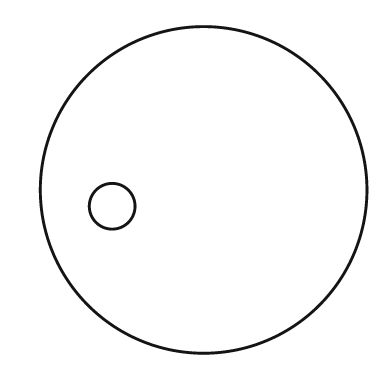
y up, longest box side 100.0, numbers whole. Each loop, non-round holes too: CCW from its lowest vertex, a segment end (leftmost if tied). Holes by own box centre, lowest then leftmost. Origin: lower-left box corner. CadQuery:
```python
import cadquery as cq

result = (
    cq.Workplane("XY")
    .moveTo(50.0, 50.0)
    .circle(50.0)
    .moveTo(22.0, 45.0)
    .circle(7.0)
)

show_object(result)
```